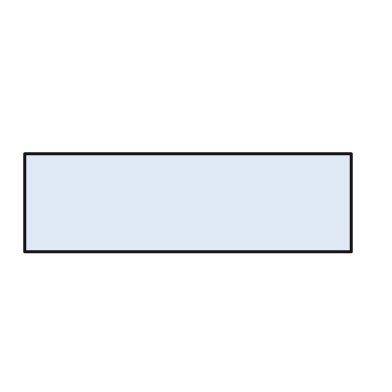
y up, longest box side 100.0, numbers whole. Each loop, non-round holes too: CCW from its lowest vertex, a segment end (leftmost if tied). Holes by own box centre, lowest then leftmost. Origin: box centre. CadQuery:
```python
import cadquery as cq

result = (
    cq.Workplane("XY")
    .moveTo(-50.0, -15.0)
    .lineTo(50.0, -15.0)
    .lineTo(50.0, 15.0)
    .lineTo(-50.0, 15.0)
    .close()
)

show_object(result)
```